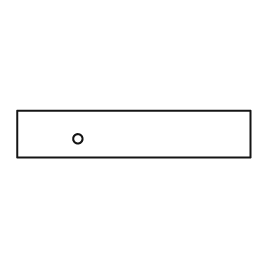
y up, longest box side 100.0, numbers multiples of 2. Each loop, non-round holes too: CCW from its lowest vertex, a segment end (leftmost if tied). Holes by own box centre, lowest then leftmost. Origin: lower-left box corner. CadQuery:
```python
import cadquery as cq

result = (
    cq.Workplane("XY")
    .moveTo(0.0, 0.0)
    .lineTo(100.0, 0.0)
    .lineTo(100.0, 20.0)
    .lineTo(0.0, 20.0)
    .close()
    .moveTo(26.0, 8.0)
    .circle(2.0)
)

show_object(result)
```